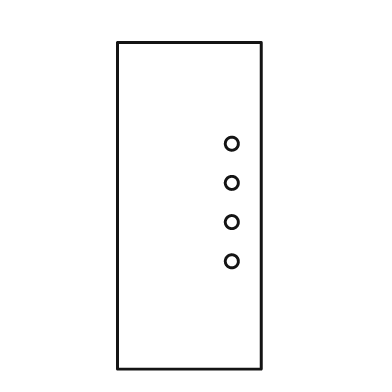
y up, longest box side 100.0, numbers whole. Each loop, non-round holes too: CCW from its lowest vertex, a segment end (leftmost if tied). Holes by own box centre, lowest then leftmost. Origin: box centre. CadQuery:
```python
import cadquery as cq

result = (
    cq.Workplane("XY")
    .moveTo(-22.0, -50.0)
    .lineTo(22.0, -50.0)
    .lineTo(22.0, 50.0)
    .lineTo(-22.0, 50.0)
    .close()
    .moveTo(13.0, -17.0)
    .circle(2.0)
    .moveTo(13.0, -5.0)
    .circle(2.0)
    .moveTo(13.0, 7.0)
    .circle(2.0)
    .moveTo(13.0, 19.0)
    .circle(2.0)
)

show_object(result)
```